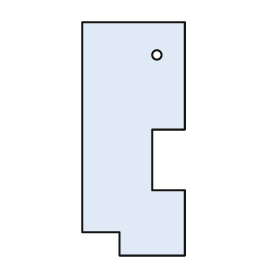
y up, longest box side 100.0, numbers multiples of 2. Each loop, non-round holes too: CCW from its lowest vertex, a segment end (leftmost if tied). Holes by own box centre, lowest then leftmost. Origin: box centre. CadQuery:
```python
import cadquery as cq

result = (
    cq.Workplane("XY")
    .moveTo(-6.0, -50.0)
    .lineTo(22.0, -50.0)
    .lineTo(22.0, -22.0)
    .lineTo(8.0, -22.0)
    .lineTo(8.0, 4.0)
    .lineTo(22.0, 4.0)
    .lineTo(22.0, 50.0)
    .lineTo(-22.0, 50.0)
    .lineTo(-22.0, -40.0)
    .lineTo(-6.0, -40.0)
    .close()
    .moveTo(10.0, 36.0)
    .circle(2.0)
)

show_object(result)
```